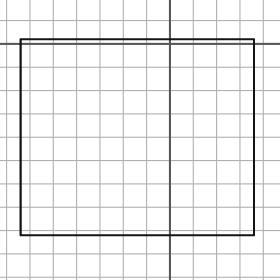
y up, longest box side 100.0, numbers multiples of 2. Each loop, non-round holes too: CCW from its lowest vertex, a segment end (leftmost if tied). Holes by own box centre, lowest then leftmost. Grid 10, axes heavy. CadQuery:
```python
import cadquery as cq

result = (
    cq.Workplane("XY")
    .moveTo(-64.0, -82.0)
    .lineTo(36.0, -82.0)
    .lineTo(36.0, 2.0)
    .lineTo(-64.0, 2.0)
    .close()
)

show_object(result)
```